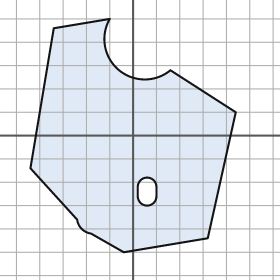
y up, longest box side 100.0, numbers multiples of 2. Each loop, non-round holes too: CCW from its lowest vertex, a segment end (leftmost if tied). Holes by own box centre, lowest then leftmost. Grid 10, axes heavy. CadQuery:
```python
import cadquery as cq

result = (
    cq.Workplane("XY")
    .moveTo(-4.0, -50.0)
    .lineTo(32.0, -44.0)
    .lineTo(44.0, 10.0)
    .lineTo(16.0, 28.0)
    .threePointArc((-6.0, 28.0), (-10.0, 50.0))
    .lineTo(-34.0, 46.0)
    .lineTo(-44.0, -14.0)
    .lineTo(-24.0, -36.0)
    .threePointArc((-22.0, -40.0), (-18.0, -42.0))
    .close()
    .moveTo(2.0, -26.0)
    .threePointArc((6.0, -30.0), (10.0, -26.0))
    .lineTo(10.0, -22.0)
    .threePointArc((6.0, -18.0), (2.0, -22.0))
    .close()
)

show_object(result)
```